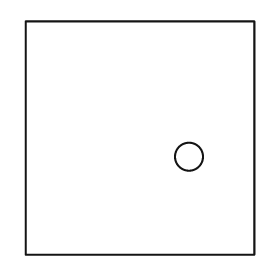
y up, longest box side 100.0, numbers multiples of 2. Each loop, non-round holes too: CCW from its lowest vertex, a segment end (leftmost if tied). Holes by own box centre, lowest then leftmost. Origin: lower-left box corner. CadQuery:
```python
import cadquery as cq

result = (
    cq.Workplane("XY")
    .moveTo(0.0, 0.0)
    .lineTo(98.0, 0.0)
    .lineTo(98.0, 100.0)
    .lineTo(0.0, 100.0)
    .close()
    .moveTo(70.0, 42.0)
    .circle(6.0)
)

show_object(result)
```